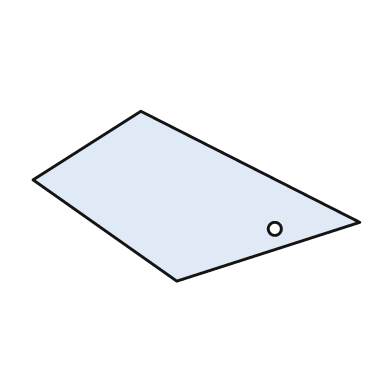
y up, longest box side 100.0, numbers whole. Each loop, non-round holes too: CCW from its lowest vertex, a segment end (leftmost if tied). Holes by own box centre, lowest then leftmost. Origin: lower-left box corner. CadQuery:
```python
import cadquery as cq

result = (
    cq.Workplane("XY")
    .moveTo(44.0, 0.0)
    .lineTo(100.0, 18.0)
    .lineTo(33.0, 52.0)
    .lineTo(0.0, 31.0)
    .close()
    .moveTo(74.0, 16.0)
    .circle(2.0)
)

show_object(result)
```